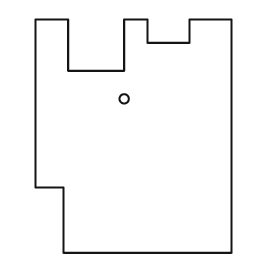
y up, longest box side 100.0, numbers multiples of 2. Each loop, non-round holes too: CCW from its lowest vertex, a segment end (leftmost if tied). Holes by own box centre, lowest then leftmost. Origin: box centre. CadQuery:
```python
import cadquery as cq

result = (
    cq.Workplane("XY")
    .moveTo(-30.0, -50.0)
    .lineTo(42.0, -50.0)
    .lineTo(42.0, 50.0)
    .lineTo(24.0, 50.0)
    .lineTo(24.0, 40.0)
    .lineTo(6.0, 40.0)
    .lineTo(6.0, 50.0)
    .lineTo(-4.0, 50.0)
    .lineTo(-4.0, 28.0)
    .lineTo(-28.0, 28.0)
    .lineTo(-28.0, 50.0)
    .lineTo(-42.0, 50.0)
    .lineTo(-42.0, -22.0)
    .lineTo(-30.0, -22.0)
    .close()
    .moveTo(-4.0, 16.0)
    .circle(2.0)
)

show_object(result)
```